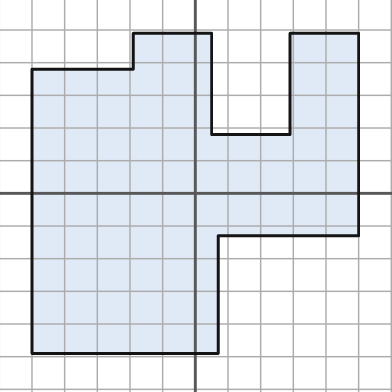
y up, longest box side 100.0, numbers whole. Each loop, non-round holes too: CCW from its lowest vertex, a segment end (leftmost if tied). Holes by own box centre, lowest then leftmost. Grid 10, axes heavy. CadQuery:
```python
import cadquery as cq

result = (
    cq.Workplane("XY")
    .moveTo(-50.0, -49.0)
    .lineTo(7.0, -49.0)
    .lineTo(7.0, -13.0)
    .lineTo(50.0, -13.0)
    .lineTo(50.0, 49.0)
    .lineTo(29.0, 49.0)
    .lineTo(29.0, 18.0)
    .lineTo(5.0, 18.0)
    .lineTo(5.0, 49.0)
    .lineTo(-19.0, 49.0)
    .lineTo(-19.0, 38.0)
    .lineTo(-50.0, 38.0)
    .close()
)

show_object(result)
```